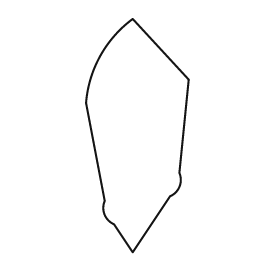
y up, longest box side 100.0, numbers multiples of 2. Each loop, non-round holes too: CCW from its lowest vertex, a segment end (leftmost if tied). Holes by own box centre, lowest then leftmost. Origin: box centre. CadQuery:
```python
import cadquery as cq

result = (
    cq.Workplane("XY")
    .moveTo(-2.0, -50.0)
    .lineTo(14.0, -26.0)
    .threePointArc((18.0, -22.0), (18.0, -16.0))
    .lineTo(22.0, 24.0)
    .lineTo(-2.0, 50.0)
    .threePointArc((-16.0, 34.0), (-22.0, 14.0))
    .lineTo(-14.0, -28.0)
    .threePointArc((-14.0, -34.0), (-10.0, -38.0))
    .close()
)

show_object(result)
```